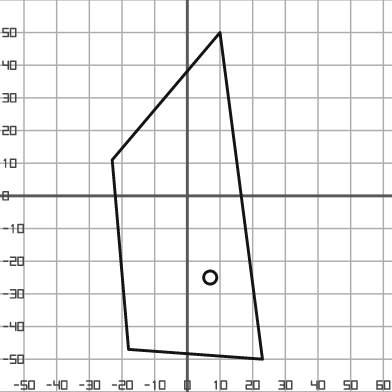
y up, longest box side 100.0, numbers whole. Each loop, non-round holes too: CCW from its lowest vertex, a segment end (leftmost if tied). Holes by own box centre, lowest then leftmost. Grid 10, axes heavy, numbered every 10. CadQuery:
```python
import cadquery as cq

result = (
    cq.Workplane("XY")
    .moveTo(23.0, -50.0)
    .lineTo(10.0, 50.0)
    .lineTo(-23.0, 11.0)
    .lineTo(-18.0, -47.0)
    .close()
    .moveTo(7.0, -25.0)
    .circle(2.0)
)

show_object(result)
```